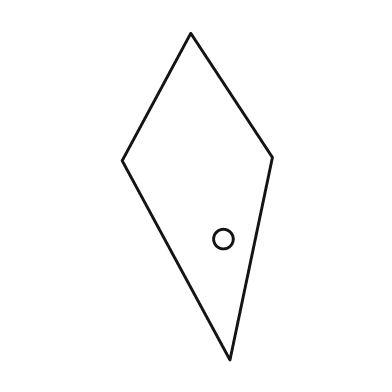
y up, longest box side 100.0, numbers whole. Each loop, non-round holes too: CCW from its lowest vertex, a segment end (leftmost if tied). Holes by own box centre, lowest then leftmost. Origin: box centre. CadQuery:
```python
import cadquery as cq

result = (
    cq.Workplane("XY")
    .moveTo(10.0, -50.0)
    .lineTo(23.0, 12.0)
    .lineTo(-2.0, 50.0)
    .lineTo(-23.0, 11.0)
    .close()
    .moveTo(8.0, -13.0)
    .circle(3.0)
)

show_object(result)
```